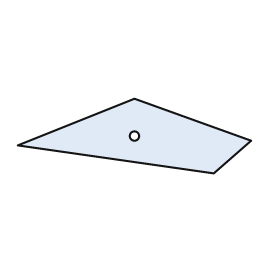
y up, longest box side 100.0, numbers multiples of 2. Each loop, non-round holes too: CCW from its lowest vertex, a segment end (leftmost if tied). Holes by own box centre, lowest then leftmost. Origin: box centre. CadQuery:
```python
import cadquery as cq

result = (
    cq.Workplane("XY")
    .moveTo(34.0, -16.0)
    .lineTo(50.0, -2.0)
    .lineTo(0.0, 16.0)
    .lineTo(-50.0, -4.0)
    .close()
    .moveTo(0.0, 0.0)
    .circle(2.0)
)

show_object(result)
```